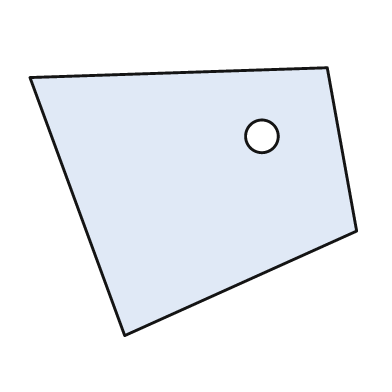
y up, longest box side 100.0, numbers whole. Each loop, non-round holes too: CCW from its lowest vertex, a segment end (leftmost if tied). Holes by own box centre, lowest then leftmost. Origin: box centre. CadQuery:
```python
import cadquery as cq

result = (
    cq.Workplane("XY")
    .moveTo(-21.0, -41.0)
    .lineTo(50.0, -9.0)
    .lineTo(41.0, 41.0)
    .lineTo(-50.0, 38.0)
    .close()
    .moveTo(21.0, 20.0)
    .circle(5.0)
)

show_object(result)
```